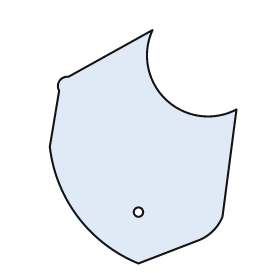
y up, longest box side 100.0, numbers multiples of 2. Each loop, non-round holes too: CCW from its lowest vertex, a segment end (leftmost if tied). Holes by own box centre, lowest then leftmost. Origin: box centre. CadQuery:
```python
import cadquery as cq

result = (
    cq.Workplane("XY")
    .moveTo(-2.0, -50.0)
    .lineTo(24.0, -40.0)
    .threePointArc((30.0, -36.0), (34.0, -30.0))
    .lineTo(40.0, 16.0)
    .threePointArc((10.0, 20.0), (4.0, 50.0))
    .lineTo(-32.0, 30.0)
    .threePointArc((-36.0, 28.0), (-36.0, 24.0))
    .lineTo(-40.0, 0.0)
    .threePointArc((-28.0, -30.0), (-2.0, -50.0))
    .close()
    .moveTo(-2.0, -28.0)
    .circle(2.0)
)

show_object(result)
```